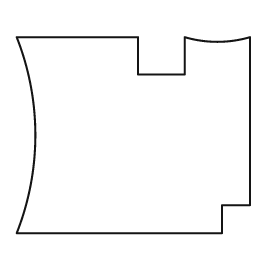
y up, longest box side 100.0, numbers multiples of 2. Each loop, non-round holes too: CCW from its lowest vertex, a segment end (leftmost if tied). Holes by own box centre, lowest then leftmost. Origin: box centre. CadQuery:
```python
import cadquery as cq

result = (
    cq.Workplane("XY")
    .moveTo(-50.0, -42.0)
    .lineTo(38.0, -42.0)
    .lineTo(38.0, -30.0)
    .lineTo(50.0, -30.0)
    .lineTo(50.0, 42.0)
    .threePointArc((36.0, 40.0), (22.0, 42.0))
    .lineTo(22.0, 26.0)
    .lineTo(2.0, 26.0)
    .lineTo(2.0, 42.0)
    .lineTo(-50.0, 42.0)
    .threePointArc((-42.0, 0.0), (-50.0, -42.0))
    .close()
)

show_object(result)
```